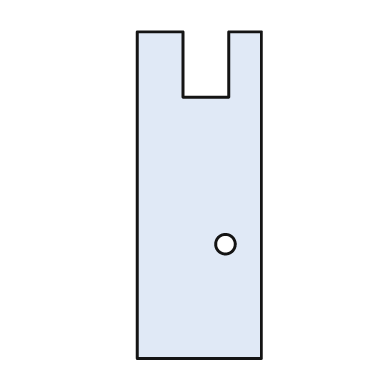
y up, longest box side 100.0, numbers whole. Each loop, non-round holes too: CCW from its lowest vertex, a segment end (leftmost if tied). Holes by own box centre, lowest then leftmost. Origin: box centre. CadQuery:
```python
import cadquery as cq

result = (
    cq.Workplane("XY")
    .moveTo(-19.0, -50.0)
    .lineTo(19.0, -50.0)
    .lineTo(19.0, 50.0)
    .lineTo(9.0, 50.0)
    .lineTo(9.0, 30.0)
    .lineTo(-5.0, 30.0)
    .lineTo(-5.0, 50.0)
    .lineTo(-19.0, 50.0)
    .close()
    .moveTo(8.0, -15.0)
    .circle(3.0)
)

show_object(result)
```